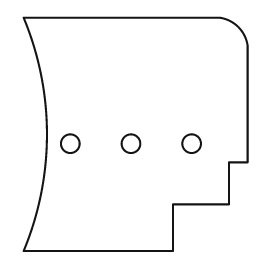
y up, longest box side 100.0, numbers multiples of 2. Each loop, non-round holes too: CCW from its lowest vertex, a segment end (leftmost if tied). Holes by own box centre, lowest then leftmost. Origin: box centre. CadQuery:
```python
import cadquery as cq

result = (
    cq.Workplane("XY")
    .moveTo(-48.0, -50.0)
    .lineTo(16.0, -50.0)
    .lineTo(16.0, -30.0)
    .lineTo(40.0, -30.0)
    .lineTo(40.0, -12.0)
    .lineTo(48.0, -12.0)
    .lineTo(48.0, 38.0)
    .threePointArc((44.0, 46.0), (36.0, 50.0))
    .lineTo(-48.0, 50.0)
    .threePointArc((-38.0, 0.0), (-48.0, -50.0))
    .close()
    .moveTo(-28.0, -4.0)
    .circle(4.0)
    .moveTo(-2.0, -4.0)
    .circle(4.0)
    .moveTo(24.0, -4.0)
    .circle(4.0)
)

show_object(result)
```